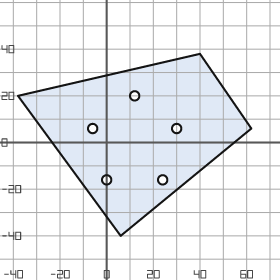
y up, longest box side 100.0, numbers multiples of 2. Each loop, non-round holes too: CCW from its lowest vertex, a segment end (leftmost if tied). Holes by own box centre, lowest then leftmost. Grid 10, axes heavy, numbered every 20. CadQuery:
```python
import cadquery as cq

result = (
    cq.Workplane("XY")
    .moveTo(6.0, -40.0)
    .lineTo(62.0, 6.0)
    .lineTo(40.0, 38.0)
    .lineTo(-38.0, 20.0)
    .close()
    .moveTo(0.0, -16.0)
    .circle(2.0)
    .moveTo(24.0, -16.0)
    .circle(2.0)
    .moveTo(-6.0, 6.0)
    .circle(2.0)
    .moveTo(30.0, 6.0)
    .circle(2.0)
    .moveTo(12.0, 20.0)
    .circle(2.0)
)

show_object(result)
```